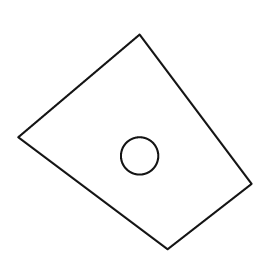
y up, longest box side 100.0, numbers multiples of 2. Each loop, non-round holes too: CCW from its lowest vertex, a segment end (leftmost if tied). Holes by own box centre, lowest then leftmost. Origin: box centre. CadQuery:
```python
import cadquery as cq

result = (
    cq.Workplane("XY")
    .moveTo(14.0, -46.0)
    .lineTo(50.0, -18.0)
    .lineTo(2.0, 46.0)
    .lineTo(-50.0, 2.0)
    .close()
    .moveTo(2.0, -6.0)
    .circle(8.0)
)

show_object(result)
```